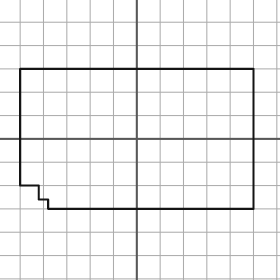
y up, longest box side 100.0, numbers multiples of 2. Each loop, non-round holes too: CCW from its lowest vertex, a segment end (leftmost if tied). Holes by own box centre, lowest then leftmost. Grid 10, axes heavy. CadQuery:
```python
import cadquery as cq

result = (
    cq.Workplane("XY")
    .moveTo(-38.0, -30.0)
    .lineTo(50.0, -30.0)
    .lineTo(50.0, 30.0)
    .lineTo(-50.0, 30.0)
    .lineTo(-50.0, -20.0)
    .lineTo(-42.0, -20.0)
    .lineTo(-42.0, -26.0)
    .lineTo(-38.0, -26.0)
    .close()
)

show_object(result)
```